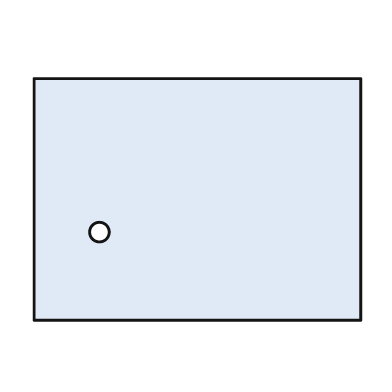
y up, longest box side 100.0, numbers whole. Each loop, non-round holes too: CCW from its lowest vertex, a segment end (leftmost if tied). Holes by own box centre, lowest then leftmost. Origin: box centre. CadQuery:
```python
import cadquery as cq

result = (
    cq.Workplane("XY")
    .moveTo(-50.0, -37.0)
    .lineTo(50.0, -37.0)
    .lineTo(50.0, 37.0)
    .lineTo(-50.0, 37.0)
    .close()
    .moveTo(-30.0, -10.0)
    .circle(3.0)
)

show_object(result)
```